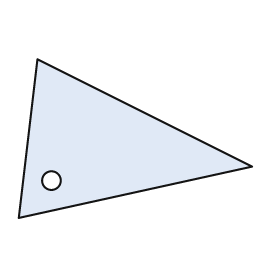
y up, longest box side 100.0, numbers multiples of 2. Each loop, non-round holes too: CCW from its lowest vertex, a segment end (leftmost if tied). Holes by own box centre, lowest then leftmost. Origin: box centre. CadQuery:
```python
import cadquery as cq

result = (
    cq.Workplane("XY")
    .moveTo(-50.0, -34.0)
    .lineTo(50.0, -12.0)
    .lineTo(-42.0, 34.0)
    .close()
    .moveTo(-36.0, -18.0)
    .circle(4.0)
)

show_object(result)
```